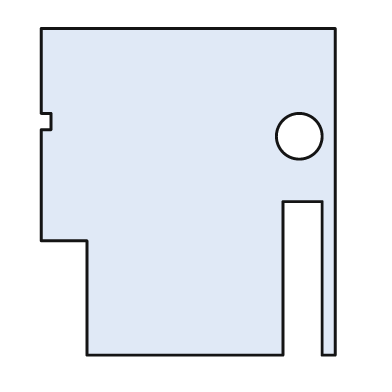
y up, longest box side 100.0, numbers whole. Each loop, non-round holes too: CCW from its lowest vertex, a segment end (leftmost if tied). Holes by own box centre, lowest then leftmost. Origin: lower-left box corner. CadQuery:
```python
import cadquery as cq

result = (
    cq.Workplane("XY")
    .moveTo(14.0, 0.0)
    .lineTo(74.0, 0.0)
    .lineTo(74.0, 47.0)
    .lineTo(86.0, 47.0)
    .lineTo(86.0, 0.0)
    .lineTo(90.0, 0.0)
    .lineTo(90.0, 100.0)
    .lineTo(0.0, 100.0)
    .lineTo(0.0, 74.0)
    .lineTo(3.0, 74.0)
    .lineTo(3.0, 69.0)
    .lineTo(0.0, 69.0)
    .lineTo(0.0, 35.0)
    .lineTo(14.0, 35.0)
    .close()
    .moveTo(79.0, 67.0)
    .circle(7.0)
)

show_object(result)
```